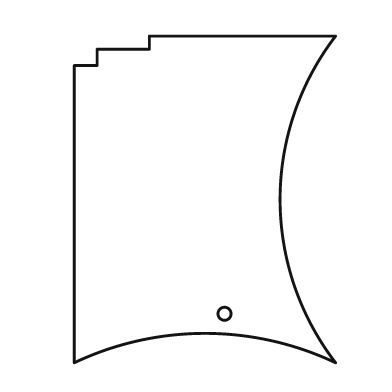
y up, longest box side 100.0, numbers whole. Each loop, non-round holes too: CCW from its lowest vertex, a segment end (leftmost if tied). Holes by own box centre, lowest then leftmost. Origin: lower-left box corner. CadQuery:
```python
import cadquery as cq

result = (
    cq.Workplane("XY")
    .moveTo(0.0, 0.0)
    .threePointArc((40.0, 9.0), (80.0, 0.0))
    .threePointArc((63.0, 50.0), (80.0, 100.0))
    .lineTo(23.0, 100.0)
    .lineTo(23.0, 96.0)
    .lineTo(7.0, 96.0)
    .lineTo(7.0, 91.0)
    .lineTo(0.0, 91.0)
    .close()
    .moveTo(46.0, 15.0)
    .circle(2.0)
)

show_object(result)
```